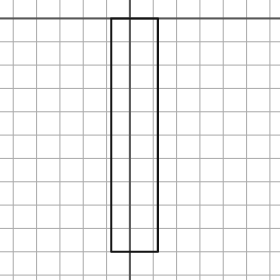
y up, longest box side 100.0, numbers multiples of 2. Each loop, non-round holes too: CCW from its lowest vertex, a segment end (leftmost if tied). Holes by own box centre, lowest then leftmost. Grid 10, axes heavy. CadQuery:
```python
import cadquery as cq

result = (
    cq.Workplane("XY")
    .moveTo(-8.0, -100.0)
    .lineTo(12.0, -100.0)
    .lineTo(12.0, 0.0)
    .lineTo(-8.0, 0.0)
    .close()
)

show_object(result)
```